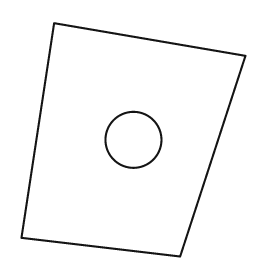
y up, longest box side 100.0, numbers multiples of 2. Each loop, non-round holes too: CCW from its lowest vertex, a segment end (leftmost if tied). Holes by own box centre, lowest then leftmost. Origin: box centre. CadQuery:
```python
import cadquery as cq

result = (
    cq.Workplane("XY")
    .moveTo(20.0, -50.0)
    .lineTo(48.0, 36.0)
    .lineTo(-34.0, 50.0)
    .lineTo(-48.0, -42.0)
    .close()
    .moveTo(0.0, 0.0)
    .circle(12.0)
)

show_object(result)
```